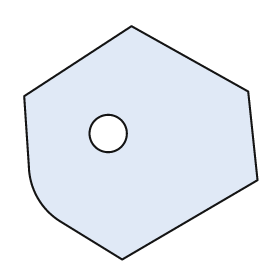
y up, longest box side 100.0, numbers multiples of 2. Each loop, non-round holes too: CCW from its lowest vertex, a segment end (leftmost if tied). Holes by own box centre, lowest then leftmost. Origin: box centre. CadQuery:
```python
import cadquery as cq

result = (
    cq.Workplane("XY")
    .moveTo(-8.0, -50.0)
    .lineTo(50.0, -16.0)
    .lineTo(46.0, 22.0)
    .lineTo(-4.0, 50.0)
    .lineTo(-50.0, 20.0)
    .lineTo(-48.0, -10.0)
    .threePointArc((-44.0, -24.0), (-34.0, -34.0))
    .close()
    .moveTo(-14.0, 4.0)
    .circle(8.0)
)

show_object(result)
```